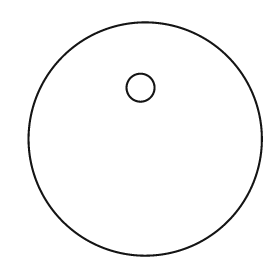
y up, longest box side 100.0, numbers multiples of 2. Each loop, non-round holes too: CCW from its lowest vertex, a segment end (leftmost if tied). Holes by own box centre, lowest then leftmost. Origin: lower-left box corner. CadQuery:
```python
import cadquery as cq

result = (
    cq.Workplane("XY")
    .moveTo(50.0, 50.0)
    .circle(50.0)
    .moveTo(48.0, 72.0)
    .circle(6.0)
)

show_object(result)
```